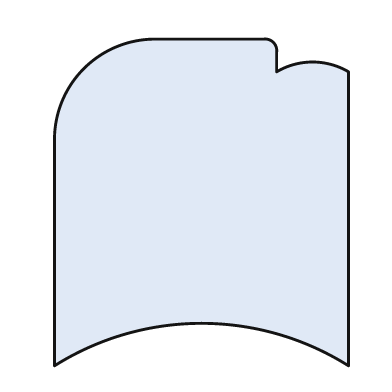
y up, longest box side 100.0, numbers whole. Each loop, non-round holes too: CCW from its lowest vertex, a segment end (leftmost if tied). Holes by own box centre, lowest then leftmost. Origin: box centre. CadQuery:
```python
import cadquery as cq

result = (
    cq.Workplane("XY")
    .moveTo(-45.0, -50.0)
    .threePointArc((0.0, -37.0), (45.0, -50.0))
    .lineTo(45.0, 40.0)
    .threePointArc((34.0, 43.0), (23.0, 40.0))
    .lineTo(23.0, 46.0)
    .threePointArc((22.0, 49.0), (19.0, 50.0))
    .lineTo(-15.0, 50.0)
    .threePointArc((-36.0, 41.0), (-45.0, 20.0))
    .close()
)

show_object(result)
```